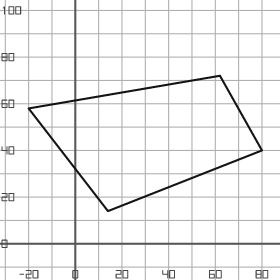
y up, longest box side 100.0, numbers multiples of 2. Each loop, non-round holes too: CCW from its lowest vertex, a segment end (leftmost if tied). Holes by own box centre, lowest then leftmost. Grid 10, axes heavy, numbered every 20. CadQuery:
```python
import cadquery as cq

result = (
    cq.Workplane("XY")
    .moveTo(14.0, 14.0)
    .lineTo(80.0, 40.0)
    .lineTo(62.0, 72.0)
    .lineTo(-20.0, 58.0)
    .close()
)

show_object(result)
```